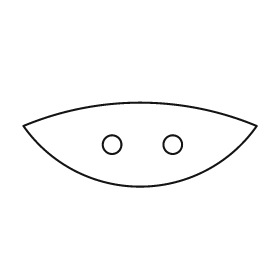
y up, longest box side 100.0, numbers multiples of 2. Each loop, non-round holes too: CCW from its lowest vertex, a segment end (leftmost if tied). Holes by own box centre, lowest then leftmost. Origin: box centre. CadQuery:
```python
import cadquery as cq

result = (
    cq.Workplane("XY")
    .moveTo(-50.0, 8.0)
    .threePointArc((0.0, -18.0), (50.0, 8.0))
    .threePointArc((0.0, 18.0), (-50.0, 8.0))
    .close()
    .moveTo(-12.0, 0.0)
    .circle(4.0)
    .moveTo(14.0, 0.0)
    .circle(4.0)
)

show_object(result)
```